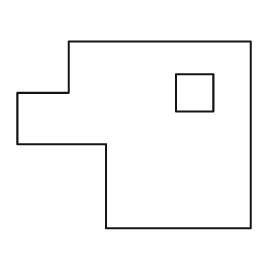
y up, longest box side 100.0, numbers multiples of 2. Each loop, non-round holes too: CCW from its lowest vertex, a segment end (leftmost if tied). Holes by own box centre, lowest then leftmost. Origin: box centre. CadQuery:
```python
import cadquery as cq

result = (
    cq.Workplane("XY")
    .moveTo(-12.0, -40.0)
    .lineTo(50.0, -40.0)
    .lineTo(50.0, 40.0)
    .lineTo(-28.0, 40.0)
    .lineTo(-28.0, 18.0)
    .lineTo(-50.0, 18.0)
    .lineTo(-50.0, -4.0)
    .lineTo(-12.0, -4.0)
    .close()
    .moveTo(18.0, 10.0)
    .lineTo(34.0, 10.0)
    .lineTo(34.0, 26.0)
    .lineTo(18.0, 26.0)
    .close()
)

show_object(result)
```